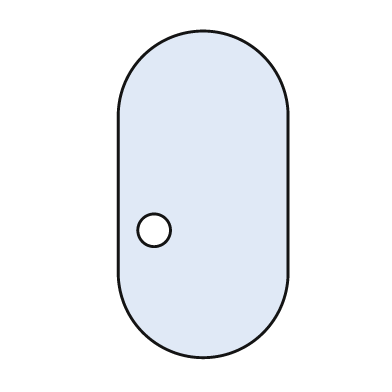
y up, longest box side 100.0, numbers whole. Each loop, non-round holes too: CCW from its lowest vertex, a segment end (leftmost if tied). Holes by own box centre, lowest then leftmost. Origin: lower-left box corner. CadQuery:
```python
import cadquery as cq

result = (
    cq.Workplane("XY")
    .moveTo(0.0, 26.0)
    .threePointArc((26.0, 0.0), (52.0, 26.0))
    .lineTo(52.0, 74.0)
    .threePointArc((26.0, 100.0), (0.0, 74.0))
    .close()
    .moveTo(11.0, 39.0)
    .circle(5.0)
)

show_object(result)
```